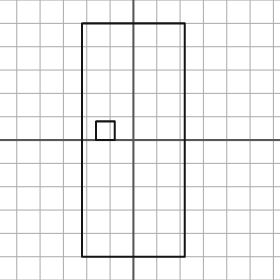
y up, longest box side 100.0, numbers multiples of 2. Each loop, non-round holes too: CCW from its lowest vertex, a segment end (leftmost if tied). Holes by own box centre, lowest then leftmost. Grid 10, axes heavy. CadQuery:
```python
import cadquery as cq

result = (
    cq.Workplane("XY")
    .moveTo(-22.0, -50.0)
    .lineTo(22.0, -50.0)
    .lineTo(22.0, 50.0)
    .lineTo(-22.0, 50.0)
    .close()
    .moveTo(-16.0, 0.0)
    .lineTo(-8.0, 0.0)
    .lineTo(-8.0, 8.0)
    .lineTo(-16.0, 8.0)
    .close()
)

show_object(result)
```